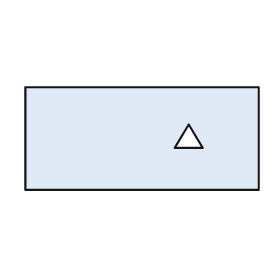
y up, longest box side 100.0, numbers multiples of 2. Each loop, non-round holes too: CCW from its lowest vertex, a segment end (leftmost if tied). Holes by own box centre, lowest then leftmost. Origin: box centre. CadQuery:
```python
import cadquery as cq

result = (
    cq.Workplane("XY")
    .moveTo(-50.0, -22.0)
    .lineTo(50.0, -22.0)
    .lineTo(50.0, 22.0)
    .lineTo(-50.0, 22.0)
    .close()
    .moveTo(14.0, -4.0)
    .lineTo(26.0, -4.0)
    .lineTo(20.0, 6.0)
    .close()
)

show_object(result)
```